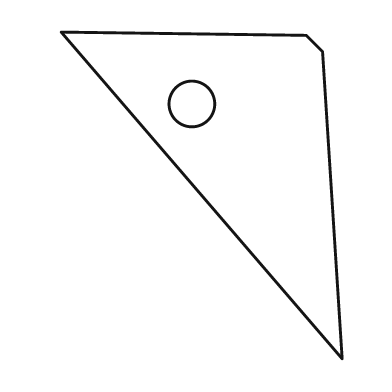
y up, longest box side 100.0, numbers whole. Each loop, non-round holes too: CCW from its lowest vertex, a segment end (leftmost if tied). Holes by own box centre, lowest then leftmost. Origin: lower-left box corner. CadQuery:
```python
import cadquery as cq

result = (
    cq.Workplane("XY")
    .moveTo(86.0, 0.0)
    .lineTo(80.0, 94.0)
    .lineTo(75.0, 99.0)
    .lineTo(0.0, 100.0)
    .close()
    .moveTo(40.0, 78.0)
    .circle(7.0)
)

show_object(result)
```